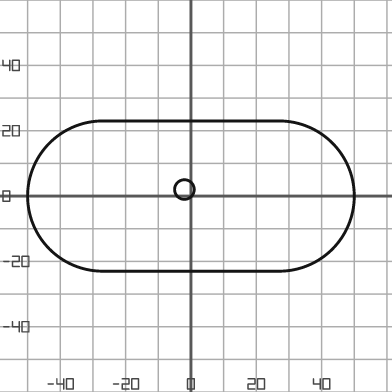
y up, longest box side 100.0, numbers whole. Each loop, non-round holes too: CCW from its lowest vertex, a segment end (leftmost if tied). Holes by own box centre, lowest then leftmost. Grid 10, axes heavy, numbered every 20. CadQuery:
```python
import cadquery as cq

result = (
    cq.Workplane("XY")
    .moveTo(-27.0, -23.0)
    .lineTo(27.0, -23.0)
    .threePointArc((50.0, 0.0), (27.0, 23.0))
    .lineTo(-27.0, 23.0)
    .threePointArc((-50.0, 0.0), (-27.0, -23.0))
    .close()
    .moveTo(-2.0, 2.0)
    .circle(3.0)
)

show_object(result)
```